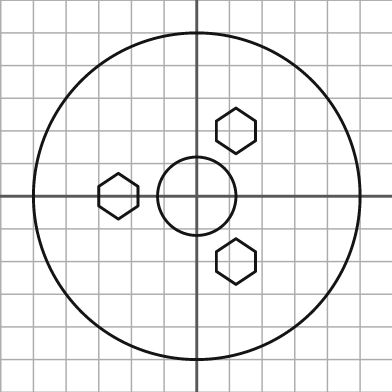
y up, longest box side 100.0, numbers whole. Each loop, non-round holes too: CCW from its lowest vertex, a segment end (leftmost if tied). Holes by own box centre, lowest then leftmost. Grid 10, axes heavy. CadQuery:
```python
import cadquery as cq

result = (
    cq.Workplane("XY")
    .moveTo(0.0, 0.0)
    .circle(50.0)
    .moveTo(12.0, -27.0)
    .lineTo(18.0, -23.0)
    .lineTo(18.0, -17.0)
    .lineTo(12.0, -13.0)
    .lineTo(6.0, -17.0)
    .lineTo(6.0, -23.0)
    .close()
    .moveTo(-24.0, -7.0)
    .lineTo(-18.0, -3.0)
    .lineTo(-18.0, 3.0)
    .lineTo(-24.0, 7.0)
    .lineTo(-30.0, 3.0)
    .lineTo(-30.0, -3.0)
    .close()
    .moveTo(0.0, 0.0)
    .circle(12.0)
    .moveTo(12.0, 13.0)
    .lineTo(18.0, 17.0)
    .lineTo(18.0, 23.0)
    .lineTo(12.0, 27.0)
    .lineTo(6.0, 23.0)
    .lineTo(6.0, 17.0)
    .close()
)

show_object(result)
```